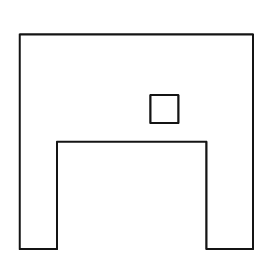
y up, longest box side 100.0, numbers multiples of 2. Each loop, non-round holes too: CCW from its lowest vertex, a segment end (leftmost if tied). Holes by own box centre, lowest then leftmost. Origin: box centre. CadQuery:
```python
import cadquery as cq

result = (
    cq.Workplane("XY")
    .moveTo(-50.0, -46.0)
    .lineTo(-34.0, -46.0)
    .lineTo(-34.0, 0.0)
    .lineTo(30.0, 0.0)
    .lineTo(30.0, -46.0)
    .lineTo(50.0, -46.0)
    .lineTo(50.0, 46.0)
    .lineTo(-50.0, 46.0)
    .close()
    .moveTo(6.0, 8.0)
    .lineTo(18.0, 8.0)
    .lineTo(18.0, 20.0)
    .lineTo(6.0, 20.0)
    .close()
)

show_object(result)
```